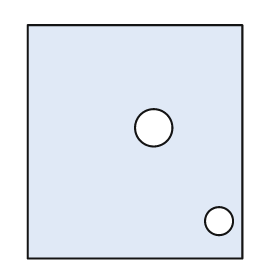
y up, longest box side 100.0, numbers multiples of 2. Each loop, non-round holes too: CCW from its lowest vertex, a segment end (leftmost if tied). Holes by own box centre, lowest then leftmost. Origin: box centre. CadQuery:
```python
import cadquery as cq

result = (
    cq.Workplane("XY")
    .moveTo(-46.0, -50.0)
    .lineTo(46.0, -50.0)
    .lineTo(46.0, 50.0)
    .lineTo(-46.0, 50.0)
    .close()
    .moveTo(36.0, -34.0)
    .circle(6.0)
    .moveTo(8.0, 6.0)
    .circle(8.0)
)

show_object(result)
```